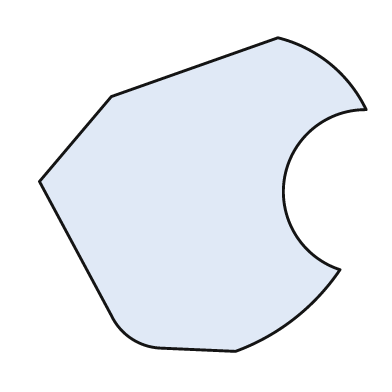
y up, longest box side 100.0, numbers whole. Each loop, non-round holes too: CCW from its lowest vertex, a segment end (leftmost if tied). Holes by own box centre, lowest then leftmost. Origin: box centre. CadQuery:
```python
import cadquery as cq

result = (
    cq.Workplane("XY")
    .moveTo(10.0, -48.0)
    .threePointArc((28.0, -38.0), (42.0, -23.0))
    .threePointArc((25.0, 5.0), (50.0, 26.0))
    .threePointArc((39.0, 40.0), (23.0, 48.0))
    .lineTo(-28.0, 30.0)
    .lineTo(-50.0, 4.0)
    .lineTo(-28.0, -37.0)
    .threePointArc((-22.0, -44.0), (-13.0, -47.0))
    .close()
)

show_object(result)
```